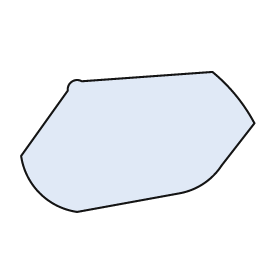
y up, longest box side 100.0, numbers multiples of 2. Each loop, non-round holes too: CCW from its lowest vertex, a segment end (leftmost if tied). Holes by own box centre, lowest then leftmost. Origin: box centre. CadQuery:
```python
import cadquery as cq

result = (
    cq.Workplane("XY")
    .moveTo(-26.0, -30.0)
    .lineTo(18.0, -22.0)
    .threePointArc((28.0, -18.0), (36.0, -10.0))
    .lineTo(50.0, 8.0)
    .threePointArc((42.0, 20.0), (32.0, 30.0))
    .lineTo(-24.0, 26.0)
    .threePointArc((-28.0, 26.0), (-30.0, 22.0))
    .lineTo(-50.0, -6.0)
    .threePointArc((-42.0, -22.0), (-26.0, -30.0))
    .close()
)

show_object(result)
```